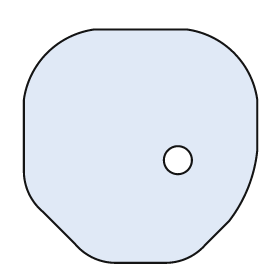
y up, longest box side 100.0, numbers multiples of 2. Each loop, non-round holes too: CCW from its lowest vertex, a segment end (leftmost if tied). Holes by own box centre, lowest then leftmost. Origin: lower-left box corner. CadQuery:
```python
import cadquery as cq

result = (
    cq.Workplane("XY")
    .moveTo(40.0, 0.0)
    .lineTo(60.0, 0.0)
    .threePointArc((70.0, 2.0), (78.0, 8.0))
    .lineTo(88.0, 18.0)
    .threePointArc((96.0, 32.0), (100.0, 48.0))
    .lineTo(100.0, 70.0)
    .threePointArc((90.0, 90.0), (70.0, 100.0))
    .lineTo(30.0, 100.0)
    .threePointArc((10.0, 90.0), (0.0, 70.0))
    .lineTo(0.0, 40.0)
    .threePointArc((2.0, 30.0), (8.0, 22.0))
    .lineTo(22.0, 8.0)
    .threePointArc((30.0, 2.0), (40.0, 0.0))
    .close()
    .moveTo(66.0, 44.0)
    .circle(6.0)
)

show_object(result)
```